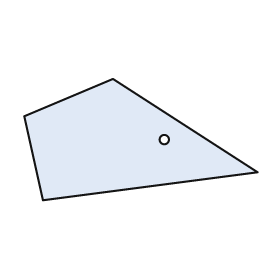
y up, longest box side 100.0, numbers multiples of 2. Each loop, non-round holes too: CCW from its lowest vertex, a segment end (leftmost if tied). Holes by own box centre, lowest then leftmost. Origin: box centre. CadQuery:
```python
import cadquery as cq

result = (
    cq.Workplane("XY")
    .moveTo(-42.0, -26.0)
    .lineTo(50.0, -14.0)
    .lineTo(-12.0, 26.0)
    .lineTo(-50.0, 10.0)
    .close()
    .moveTo(10.0, 0.0)
    .circle(2.0)
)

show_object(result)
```